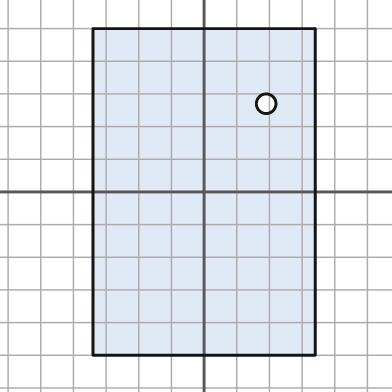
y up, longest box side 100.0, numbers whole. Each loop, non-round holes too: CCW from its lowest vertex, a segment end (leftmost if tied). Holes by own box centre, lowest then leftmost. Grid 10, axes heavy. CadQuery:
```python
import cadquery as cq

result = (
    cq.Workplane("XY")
    .moveTo(-34.0, -50.0)
    .lineTo(34.0, -50.0)
    .lineTo(34.0, 50.0)
    .lineTo(-34.0, 50.0)
    .close()
    .moveTo(19.0, 27.0)
    .circle(3.0)
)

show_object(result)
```